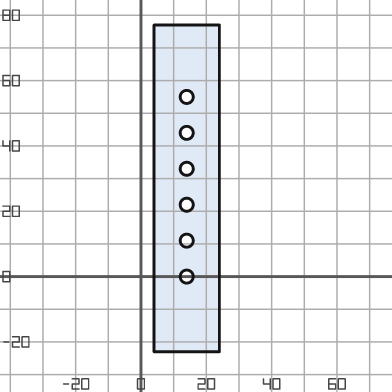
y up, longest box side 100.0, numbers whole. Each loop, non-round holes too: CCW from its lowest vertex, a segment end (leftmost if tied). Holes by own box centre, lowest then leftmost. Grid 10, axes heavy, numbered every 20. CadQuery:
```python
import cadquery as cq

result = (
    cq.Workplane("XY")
    .moveTo(4.0, -23.0)
    .lineTo(24.0, -23.0)
    .lineTo(24.0, 77.0)
    .lineTo(4.0, 77.0)
    .close()
    .moveTo(14.0, 0.0)
    .circle(2.0)
    .moveTo(14.0, 11.0)
    .circle(2.0)
    .moveTo(14.0, 22.0)
    .circle(2.0)
    .moveTo(14.0, 33.0)
    .circle(2.0)
    .moveTo(14.0, 44.0)
    .circle(2.0)
    .moveTo(14.0, 55.0)
    .circle(2.0)
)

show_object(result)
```